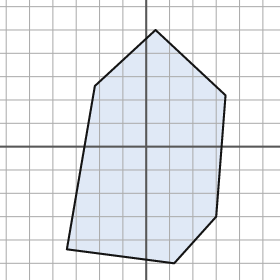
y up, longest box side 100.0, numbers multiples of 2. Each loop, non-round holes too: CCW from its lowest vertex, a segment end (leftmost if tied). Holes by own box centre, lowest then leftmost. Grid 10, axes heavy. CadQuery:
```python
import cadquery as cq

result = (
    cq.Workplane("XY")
    .moveTo(12.0, -50.0)
    .lineTo(30.0, -30.0)
    .lineTo(34.0, 22.0)
    .lineTo(4.0, 50.0)
    .lineTo(-22.0, 26.0)
    .lineTo(-34.0, -44.0)
    .close()
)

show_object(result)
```